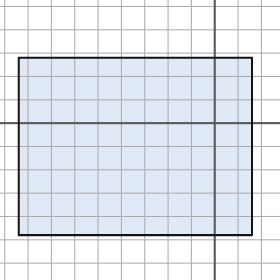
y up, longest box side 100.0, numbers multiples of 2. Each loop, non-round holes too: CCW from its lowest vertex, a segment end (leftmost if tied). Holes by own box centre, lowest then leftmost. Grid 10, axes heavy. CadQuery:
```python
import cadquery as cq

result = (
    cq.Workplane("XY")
    .moveTo(-84.0, -48.0)
    .lineTo(16.0, -48.0)
    .lineTo(16.0, 28.0)
    .lineTo(-84.0, 28.0)
    .close()
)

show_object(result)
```